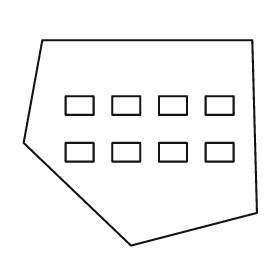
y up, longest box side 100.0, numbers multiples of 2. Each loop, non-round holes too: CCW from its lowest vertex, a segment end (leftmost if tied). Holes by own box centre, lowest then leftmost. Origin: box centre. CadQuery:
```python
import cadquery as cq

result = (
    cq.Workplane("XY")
    .moveTo(-4.0, -44.0)
    .lineTo(50.0, -30.0)
    .lineTo(48.0, 44.0)
    .lineTo(-42.0, 44.0)
    .lineTo(-50.0, 0.0)
    .close()
    .moveTo(-32.0, -8.0)
    .lineTo(-20.0, -8.0)
    .lineTo(-20.0, 0.0)
    .lineTo(-32.0, 0.0)
    .close()
    .moveTo(-12.0, -8.0)
    .lineTo(0.0, -8.0)
    .lineTo(0.0, 0.0)
    .lineTo(-12.0, 0.0)
    .close()
    .moveTo(8.0, -8.0)
    .lineTo(20.0, -8.0)
    .lineTo(20.0, 0.0)
    .lineTo(8.0, 0.0)
    .close()
    .moveTo(28.0, -8.0)
    .lineTo(40.0, -8.0)
    .lineTo(40.0, 0.0)
    .lineTo(28.0, 0.0)
    .close()
    .moveTo(-32.0, 12.0)
    .lineTo(-20.0, 12.0)
    .lineTo(-20.0, 20.0)
    .lineTo(-32.0, 20.0)
    .close()
    .moveTo(-12.0, 12.0)
    .lineTo(0.0, 12.0)
    .lineTo(0.0, 20.0)
    .lineTo(-12.0, 20.0)
    .close()
    .moveTo(8.0, 12.0)
    .lineTo(20.0, 12.0)
    .lineTo(20.0, 20.0)
    .lineTo(8.0, 20.0)
    .close()
    .moveTo(28.0, 12.0)
    .lineTo(40.0, 12.0)
    .lineTo(40.0, 20.0)
    .lineTo(28.0, 20.0)
    .close()
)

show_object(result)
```